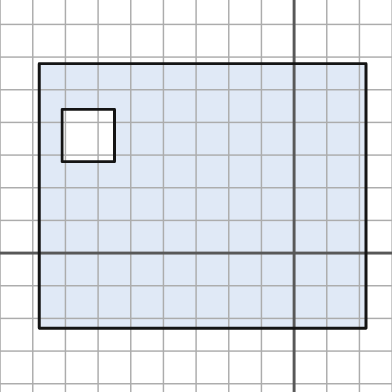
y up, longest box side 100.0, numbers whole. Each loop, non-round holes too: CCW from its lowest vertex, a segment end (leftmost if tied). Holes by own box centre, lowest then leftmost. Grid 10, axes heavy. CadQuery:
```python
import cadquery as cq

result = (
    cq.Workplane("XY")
    .moveTo(-78.0, -23.0)
    .lineTo(22.0, -23.0)
    .lineTo(22.0, 58.0)
    .lineTo(-78.0, 58.0)
    .close()
    .moveTo(-71.0, 28.0)
    .lineTo(-55.0, 28.0)
    .lineTo(-55.0, 44.0)
    .lineTo(-71.0, 44.0)
    .close()
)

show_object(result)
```